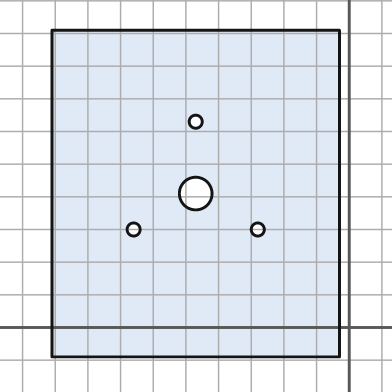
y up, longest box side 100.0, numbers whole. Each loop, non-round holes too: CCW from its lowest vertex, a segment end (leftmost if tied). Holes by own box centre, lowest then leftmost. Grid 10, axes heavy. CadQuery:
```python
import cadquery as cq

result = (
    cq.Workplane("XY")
    .moveTo(-91.0, -9.0)
    .lineTo(-3.0, -9.0)
    .lineTo(-3.0, 91.0)
    .lineTo(-91.0, 91.0)
    .close()
    .moveTo(-66.0, 30.0)
    .circle(2.0)
    .moveTo(-28.0, 30.0)
    .circle(2.0)
    .moveTo(-47.0, 41.0)
    .circle(5.0)
    .moveTo(-47.0, 63.0)
    .circle(2.0)
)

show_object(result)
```